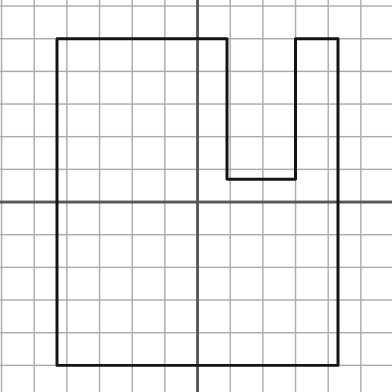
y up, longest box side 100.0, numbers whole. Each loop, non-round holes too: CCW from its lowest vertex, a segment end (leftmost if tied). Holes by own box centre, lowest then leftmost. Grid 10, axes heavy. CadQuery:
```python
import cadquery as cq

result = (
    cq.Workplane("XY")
    .moveTo(-43.0, -50.0)
    .lineTo(43.0, -50.0)
    .lineTo(43.0, 50.0)
    .lineTo(30.0, 50.0)
    .lineTo(30.0, 7.0)
    .lineTo(9.0, 7.0)
    .lineTo(9.0, 50.0)
    .lineTo(-43.0, 50.0)
    .close()
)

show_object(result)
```